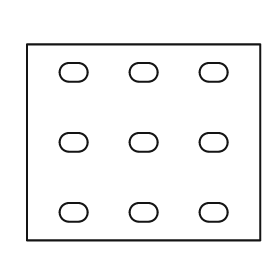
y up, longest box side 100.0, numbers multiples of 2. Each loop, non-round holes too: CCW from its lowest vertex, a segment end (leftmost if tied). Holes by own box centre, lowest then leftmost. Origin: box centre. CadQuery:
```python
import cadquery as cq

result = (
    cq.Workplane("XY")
    .moveTo(-50.0, -42.0)
    .lineTo(50.0, -42.0)
    .lineTo(50.0, 42.0)
    .lineTo(-50.0, 42.0)
    .close()
    .moveTo(-32.0, -34.0)
    .lineTo(-28.0, -34.0)
    .threePointArc((-24.0, -30.0), (-28.0, -26.0))
    .lineTo(-32.0, -26.0)
    .threePointArc((-36.0, -30.0), (-32.0, -34.0))
    .close()
    .moveTo(-2.0, -34.0)
    .lineTo(2.0, -34.0)
    .threePointArc((6.0, -30.0), (2.0, -26.0))
    .lineTo(-2.0, -26.0)
    .threePointArc((-6.0, -30.0), (-2.0, -34.0))
    .close()
    .moveTo(28.0, -34.0)
    .lineTo(32.0, -34.0)
    .threePointArc((36.0, -30.0), (32.0, -26.0))
    .lineTo(28.0, -26.0)
    .threePointArc((24.0, -30.0), (28.0, -34.0))
    .close()
    .moveTo(-32.0, -4.0)
    .lineTo(-28.0, -4.0)
    .threePointArc((-24.0, 0.0), (-28.0, 4.0))
    .lineTo(-32.0, 4.0)
    .threePointArc((-36.0, 0.0), (-32.0, -4.0))
    .close()
    .moveTo(-2.0, -4.0)
    .lineTo(2.0, -4.0)
    .threePointArc((6.0, 0.0), (2.0, 4.0))
    .lineTo(-2.0, 4.0)
    .threePointArc((-6.0, 0.0), (-2.0, -4.0))
    .close()
    .moveTo(28.0, -4.0)
    .lineTo(32.0, -4.0)
    .threePointArc((36.0, 0.0), (32.0, 4.0))
    .lineTo(28.0, 4.0)
    .threePointArc((24.0, 0.0), (28.0, -4.0))
    .close()
    .moveTo(-32.0, 26.0)
    .lineTo(-28.0, 26.0)
    .threePointArc((-24.0, 30.0), (-28.0, 34.0))
    .lineTo(-32.0, 34.0)
    .threePointArc((-36.0, 30.0), (-32.0, 26.0))
    .close()
    .moveTo(-2.0, 26.0)
    .lineTo(2.0, 26.0)
    .threePointArc((6.0, 30.0), (2.0, 34.0))
    .lineTo(-2.0, 34.0)
    .threePointArc((-6.0, 30.0), (-2.0, 26.0))
    .close()
    .moveTo(28.0, 26.0)
    .lineTo(32.0, 26.0)
    .threePointArc((36.0, 30.0), (32.0, 34.0))
    .lineTo(28.0, 34.0)
    .threePointArc((24.0, 30.0), (28.0, 26.0))
    .close()
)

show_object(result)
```